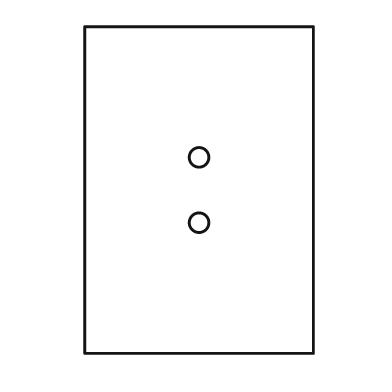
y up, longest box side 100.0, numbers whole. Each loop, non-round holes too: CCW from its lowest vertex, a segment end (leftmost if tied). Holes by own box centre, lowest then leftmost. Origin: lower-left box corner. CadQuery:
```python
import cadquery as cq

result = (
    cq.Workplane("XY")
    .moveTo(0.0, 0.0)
    .lineTo(70.0, 0.0)
    .lineTo(70.0, 100.0)
    .lineTo(0.0, 100.0)
    .close()
    .moveTo(35.0, 40.0)
    .circle(3.0)
    .moveTo(35.0, 60.0)
    .circle(3.0)
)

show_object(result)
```